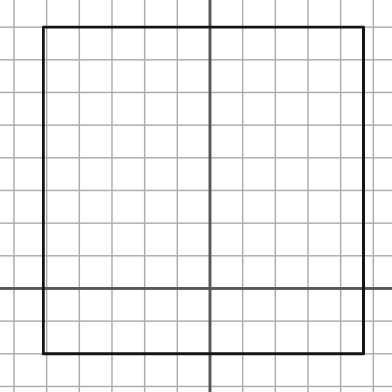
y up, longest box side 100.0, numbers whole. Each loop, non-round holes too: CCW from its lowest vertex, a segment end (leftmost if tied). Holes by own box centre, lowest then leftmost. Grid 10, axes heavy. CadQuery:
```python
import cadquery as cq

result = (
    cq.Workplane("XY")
    .moveTo(-51.0, -20.0)
    .lineTo(47.0, -20.0)
    .lineTo(47.0, 80.0)
    .lineTo(-51.0, 80.0)
    .close()
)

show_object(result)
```